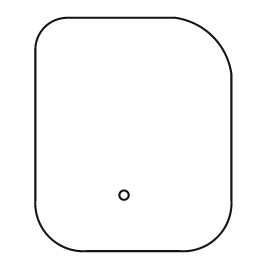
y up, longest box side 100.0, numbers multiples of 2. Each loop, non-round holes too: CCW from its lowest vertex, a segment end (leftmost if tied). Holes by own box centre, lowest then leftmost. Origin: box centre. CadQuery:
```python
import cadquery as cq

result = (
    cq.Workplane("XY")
    .moveTo(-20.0, -50.0)
    .lineTo(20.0, -50.0)
    .threePointArc((36.0, -44.0), (42.0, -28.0))
    .lineTo(42.0, 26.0)
    .threePointArc((34.0, 42.0), (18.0, 50.0))
    .lineTo(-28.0, 50.0)
    .threePointArc((-38.0, 46.0), (-42.0, 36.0))
    .lineTo(-42.0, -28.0)
    .threePointArc((-36.0, -44.0), (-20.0, -50.0))
    .close()
    .moveTo(-4.0, -26.0)
    .circle(2.0)
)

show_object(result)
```